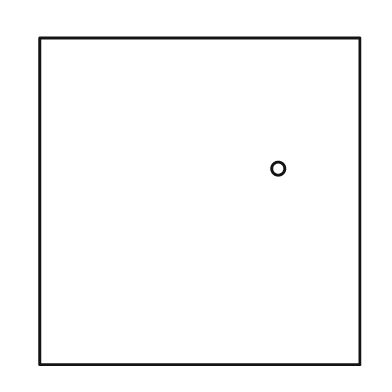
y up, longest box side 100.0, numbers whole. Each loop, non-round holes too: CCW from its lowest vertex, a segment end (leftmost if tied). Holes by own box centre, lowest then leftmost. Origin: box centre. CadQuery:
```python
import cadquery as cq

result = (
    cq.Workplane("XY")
    .moveTo(-49.0, -50.0)
    .lineTo(49.0, -50.0)
    .lineTo(49.0, 50.0)
    .lineTo(-49.0, 50.0)
    .close()
    .moveTo(24.0, 10.0)
    .circle(2.0)
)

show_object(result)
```